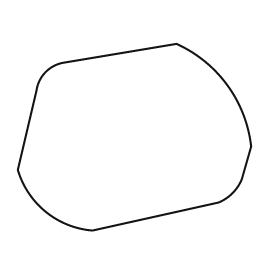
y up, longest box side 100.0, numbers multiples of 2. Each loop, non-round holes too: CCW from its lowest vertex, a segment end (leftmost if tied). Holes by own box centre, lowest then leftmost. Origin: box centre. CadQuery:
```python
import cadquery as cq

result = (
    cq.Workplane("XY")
    .moveTo(-18.0, -40.0)
    .lineTo(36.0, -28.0)
    .threePointArc((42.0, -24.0), (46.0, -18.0))
    .lineTo(50.0, -4.0)
    .threePointArc((40.0, 22.0), (18.0, 40.0))
    .lineTo(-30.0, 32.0)
    .threePointArc((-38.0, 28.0), (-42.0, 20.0))
    .lineTo(-50.0, -14.0)
    .threePointArc((-38.0, -32.0), (-18.0, -40.0))
    .close()
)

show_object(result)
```